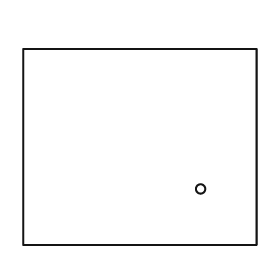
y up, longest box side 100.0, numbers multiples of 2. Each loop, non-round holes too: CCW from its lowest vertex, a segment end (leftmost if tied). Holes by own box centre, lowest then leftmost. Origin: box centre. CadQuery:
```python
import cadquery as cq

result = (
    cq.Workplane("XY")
    .moveTo(-50.0, -42.0)
    .lineTo(50.0, -42.0)
    .lineTo(50.0, 42.0)
    .lineTo(-50.0, 42.0)
    .close()
    .moveTo(26.0, -18.0)
    .circle(2.0)
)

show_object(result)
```